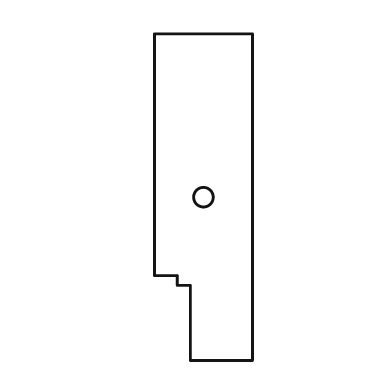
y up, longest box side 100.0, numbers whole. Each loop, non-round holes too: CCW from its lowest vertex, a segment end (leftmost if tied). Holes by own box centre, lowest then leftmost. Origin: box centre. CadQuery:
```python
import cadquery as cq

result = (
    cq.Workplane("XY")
    .moveTo(-4.0, -50.0)
    .lineTo(15.0, -50.0)
    .lineTo(15.0, 50.0)
    .lineTo(-15.0, 50.0)
    .lineTo(-15.0, -24.0)
    .lineTo(-8.0, -24.0)
    .lineTo(-8.0, -27.0)
    .lineTo(-4.0, -27.0)
    .close()
    .moveTo(0.0, 0.0)
    .circle(3.0)
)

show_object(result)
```